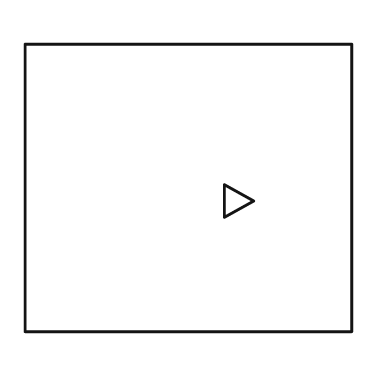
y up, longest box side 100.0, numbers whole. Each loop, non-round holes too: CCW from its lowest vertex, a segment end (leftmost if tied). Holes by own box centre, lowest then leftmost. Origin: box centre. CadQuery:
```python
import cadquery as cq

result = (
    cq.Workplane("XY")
    .moveTo(-50.0, -44.0)
    .lineTo(50.0, -44.0)
    .lineTo(50.0, 44.0)
    .lineTo(-50.0, 44.0)
    .close()
    .moveTo(11.0, -9.0)
    .lineTo(20.0, -4.0)
    .lineTo(11.0, 1.0)
    .close()
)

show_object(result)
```